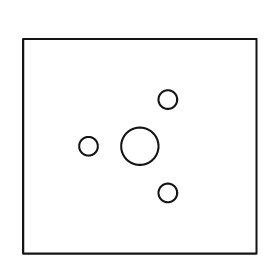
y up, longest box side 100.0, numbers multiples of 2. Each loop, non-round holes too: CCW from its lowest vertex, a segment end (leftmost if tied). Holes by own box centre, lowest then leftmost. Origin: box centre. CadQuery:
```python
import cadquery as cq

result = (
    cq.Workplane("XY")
    .moveTo(-50.0, -46.0)
    .lineTo(50.0, -46.0)
    .lineTo(50.0, 46.0)
    .lineTo(-50.0, 46.0)
    .close()
    .moveTo(12.0, -20.0)
    .circle(4.0)
    .moveTo(-22.0, 0.0)
    .circle(4.0)
    .moveTo(0.0, 0.0)
    .circle(8.0)
    .moveTo(12.0, 20.0)
    .circle(4.0)
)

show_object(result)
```